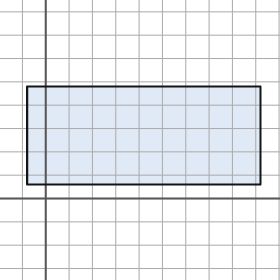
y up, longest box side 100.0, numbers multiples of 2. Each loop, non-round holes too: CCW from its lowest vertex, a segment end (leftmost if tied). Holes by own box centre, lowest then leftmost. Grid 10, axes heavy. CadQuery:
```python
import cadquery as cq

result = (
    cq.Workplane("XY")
    .moveTo(-8.0, 6.0)
    .lineTo(92.0, 6.0)
    .lineTo(92.0, 48.0)
    .lineTo(-8.0, 48.0)
    .close()
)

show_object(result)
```